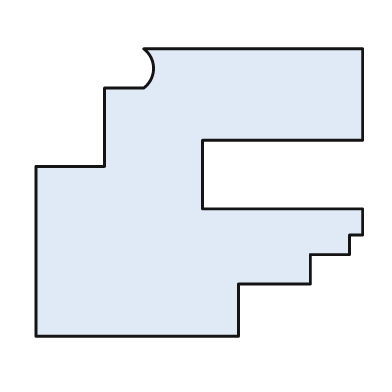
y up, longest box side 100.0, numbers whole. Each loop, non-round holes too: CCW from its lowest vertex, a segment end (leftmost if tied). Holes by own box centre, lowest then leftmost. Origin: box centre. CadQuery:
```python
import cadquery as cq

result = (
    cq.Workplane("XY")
    .moveTo(-50.0, -44.0)
    .lineTo(12.0, -44.0)
    .lineTo(12.0, -28.0)
    .lineTo(34.0, -28.0)
    .lineTo(34.0, -19.0)
    .lineTo(46.0, -19.0)
    .lineTo(46.0, -13.0)
    .lineTo(50.0, -13.0)
    .lineTo(50.0, -5.0)
    .lineTo(1.0, -5.0)
    .lineTo(1.0, 16.0)
    .lineTo(50.0, 16.0)
    .lineTo(50.0, 44.0)
    .lineTo(-17.0, 44.0)
    .threePointArc((-14.0, 38.0), (-17.0, 32.0))
    .lineTo(-29.0, 32.0)
    .lineTo(-29.0, 8.0)
    .lineTo(-50.0, 8.0)
    .close()
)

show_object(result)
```